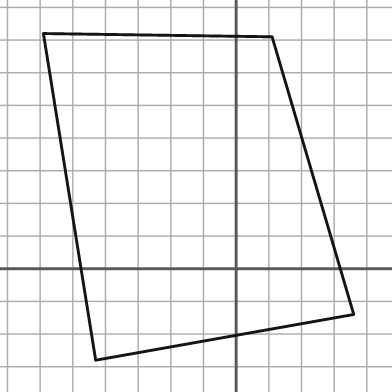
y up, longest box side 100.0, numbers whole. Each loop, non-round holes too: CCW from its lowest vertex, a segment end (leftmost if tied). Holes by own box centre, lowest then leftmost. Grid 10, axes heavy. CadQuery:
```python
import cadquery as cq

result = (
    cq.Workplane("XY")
    .moveTo(-43.0, -28.0)
    .lineTo(36.0, -14.0)
    .lineTo(11.0, 71.0)
    .lineTo(-59.0, 72.0)
    .close()
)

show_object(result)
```